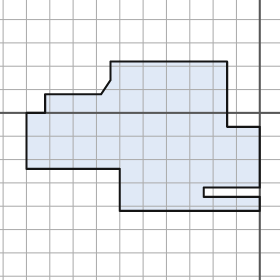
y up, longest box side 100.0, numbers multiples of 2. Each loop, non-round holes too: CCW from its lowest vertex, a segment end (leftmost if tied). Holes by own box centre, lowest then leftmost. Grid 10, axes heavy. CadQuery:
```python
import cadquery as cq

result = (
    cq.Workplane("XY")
    .moveTo(-60.0, -42.0)
    .lineTo(0.0, -42.0)
    .lineTo(0.0, -36.0)
    .lineTo(-24.0, -36.0)
    .lineTo(-24.0, -32.0)
    .lineTo(0.0, -32.0)
    .lineTo(0.0, -6.0)
    .lineTo(-14.0, -6.0)
    .lineTo(-14.0, 22.0)
    .lineTo(-64.0, 22.0)
    .lineTo(-64.0, 14.0)
    .lineTo(-68.0, 8.0)
    .lineTo(-92.0, 8.0)
    .lineTo(-92.0, 0.0)
    .lineTo(-100.0, 0.0)
    .lineTo(-100.0, -24.0)
    .lineTo(-60.0, -24.0)
    .close()
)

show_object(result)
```